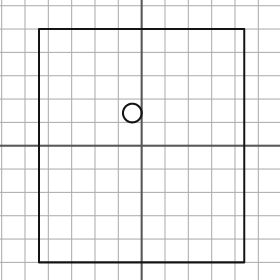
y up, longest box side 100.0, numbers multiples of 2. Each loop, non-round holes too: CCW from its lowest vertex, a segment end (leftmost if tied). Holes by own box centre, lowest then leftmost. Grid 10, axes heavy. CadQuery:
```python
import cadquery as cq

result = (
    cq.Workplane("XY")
    .moveTo(-44.0, -50.0)
    .lineTo(44.0, -50.0)
    .lineTo(44.0, 50.0)
    .lineTo(-44.0, 50.0)
    .close()
    .moveTo(-4.0, 14.0)
    .circle(4.0)
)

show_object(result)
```